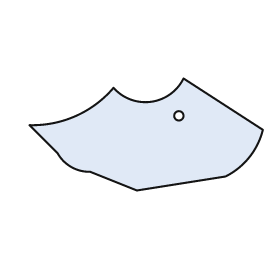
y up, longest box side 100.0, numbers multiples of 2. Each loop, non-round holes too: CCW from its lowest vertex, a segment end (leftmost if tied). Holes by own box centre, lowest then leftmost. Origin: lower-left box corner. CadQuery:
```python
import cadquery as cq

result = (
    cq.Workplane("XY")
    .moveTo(46.0, 0.0)
    .lineTo(84.0, 6.0)
    .threePointArc((94.0, 14.0), (100.0, 26.0))
    .lineTo(66.0, 48.0)
    .threePointArc((52.0, 38.0), (36.0, 44.0))
    .threePointArc((20.0, 32.0), (0.0, 28.0))
    .lineTo(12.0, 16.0)
    .threePointArc((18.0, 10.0), (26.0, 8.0))
    .close()
    .moveTo(64.0, 32.0)
    .circle(2.0)
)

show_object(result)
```